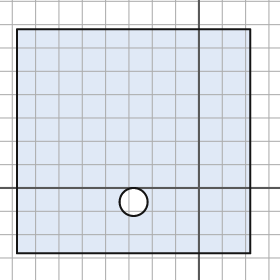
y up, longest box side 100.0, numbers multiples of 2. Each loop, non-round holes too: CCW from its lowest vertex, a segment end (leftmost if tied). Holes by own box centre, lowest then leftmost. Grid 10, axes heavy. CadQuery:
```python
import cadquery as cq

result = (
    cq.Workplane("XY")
    .moveTo(-78.0, -28.0)
    .lineTo(22.0, -28.0)
    .lineTo(22.0, 68.0)
    .lineTo(-78.0, 68.0)
    .close()
    .moveTo(-28.0, -6.0)
    .circle(6.0)
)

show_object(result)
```